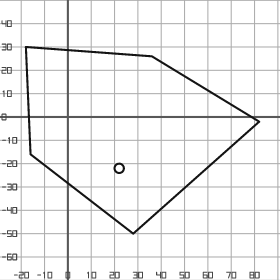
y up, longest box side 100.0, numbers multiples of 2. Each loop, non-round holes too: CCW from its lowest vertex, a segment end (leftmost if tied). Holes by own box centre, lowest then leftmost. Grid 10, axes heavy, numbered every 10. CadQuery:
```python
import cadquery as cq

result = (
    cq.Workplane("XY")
    .moveTo(28.0, -50.0)
    .lineTo(82.0, -2.0)
    .lineTo(36.0, 26.0)
    .lineTo(-18.0, 30.0)
    .lineTo(-16.0, -16.0)
    .close()
    .moveTo(22.0, -22.0)
    .circle(2.0)
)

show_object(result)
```